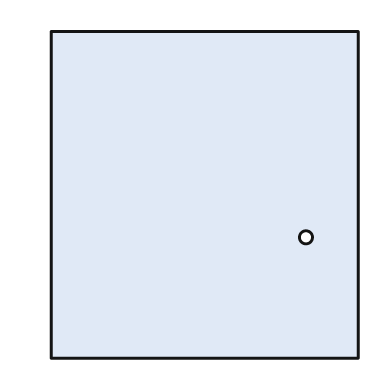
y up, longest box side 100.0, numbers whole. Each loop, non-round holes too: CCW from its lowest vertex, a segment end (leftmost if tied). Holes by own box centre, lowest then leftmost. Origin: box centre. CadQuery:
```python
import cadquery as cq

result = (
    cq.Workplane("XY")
    .moveTo(-47.0, -50.0)
    .lineTo(47.0, -50.0)
    .lineTo(47.0, 50.0)
    .lineTo(-47.0, 50.0)
    .close()
    .moveTo(31.0, -13.0)
    .circle(2.0)
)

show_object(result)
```